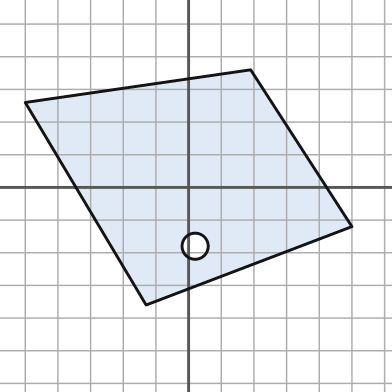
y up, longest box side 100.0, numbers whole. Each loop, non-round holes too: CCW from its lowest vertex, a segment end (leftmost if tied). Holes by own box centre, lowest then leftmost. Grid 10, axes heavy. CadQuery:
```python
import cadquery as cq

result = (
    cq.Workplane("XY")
    .moveTo(-13.0, -36.0)
    .lineTo(50.0, -12.0)
    .lineTo(19.0, 36.0)
    .lineTo(-50.0, 26.0)
    .close()
    .moveTo(2.0, -18.0)
    .circle(4.0)
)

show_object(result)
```